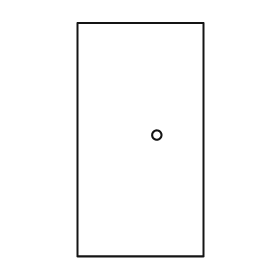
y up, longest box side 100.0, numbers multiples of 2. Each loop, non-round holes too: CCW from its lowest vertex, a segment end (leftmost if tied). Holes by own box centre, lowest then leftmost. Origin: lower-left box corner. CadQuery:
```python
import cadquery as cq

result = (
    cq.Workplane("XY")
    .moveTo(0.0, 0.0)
    .lineTo(54.0, 0.0)
    .lineTo(54.0, 100.0)
    .lineTo(0.0, 100.0)
    .close()
    .moveTo(34.0, 52.0)
    .circle(2.0)
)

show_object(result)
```